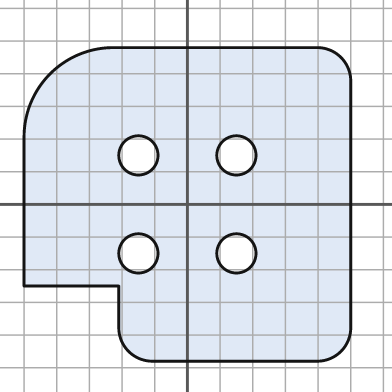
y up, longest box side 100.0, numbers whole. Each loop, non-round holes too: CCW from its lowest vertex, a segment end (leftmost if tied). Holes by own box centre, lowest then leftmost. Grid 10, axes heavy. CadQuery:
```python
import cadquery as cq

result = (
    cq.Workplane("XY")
    .moveTo(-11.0, -48.0)
    .lineTo(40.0, -48.0)
    .threePointArc((47.0, -45.0), (50.0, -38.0))
    .lineTo(50.0, 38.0)
    .threePointArc((47.0, 45.0), (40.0, 48.0))
    .lineTo(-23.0, 48.0)
    .threePointArc((-42.0, 40.0), (-50.0, 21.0))
    .lineTo(-50.0, -25.0)
    .lineTo(-21.0, -25.0)
    .lineTo(-21.0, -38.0)
    .threePointArc((-18.0, -45.0), (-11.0, -48.0))
    .close()
    .moveTo(-15.0, -15.0)
    .circle(6.0)
    .moveTo(15.0, -15.0)
    .circle(6.0)
    .moveTo(-15.0, 15.0)
    .circle(6.0)
    .moveTo(15.0, 15.0)
    .circle(6.0)
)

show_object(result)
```